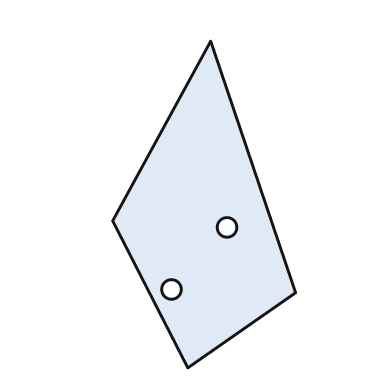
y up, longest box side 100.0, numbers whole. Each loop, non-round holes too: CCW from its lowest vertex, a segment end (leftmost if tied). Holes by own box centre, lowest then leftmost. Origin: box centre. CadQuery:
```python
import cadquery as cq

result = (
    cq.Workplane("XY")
    .moveTo(-5.0, -50.0)
    .lineTo(28.0, -27.0)
    .lineTo(2.0, 50.0)
    .lineTo(-28.0, -5.0)
    .close()
    .moveTo(-10.0, -26.0)
    .circle(3.0)
    .moveTo(7.0, -7.0)
    .circle(3.0)
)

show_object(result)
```